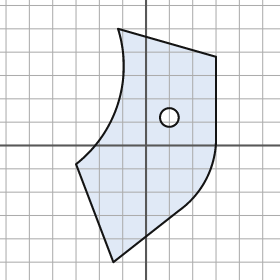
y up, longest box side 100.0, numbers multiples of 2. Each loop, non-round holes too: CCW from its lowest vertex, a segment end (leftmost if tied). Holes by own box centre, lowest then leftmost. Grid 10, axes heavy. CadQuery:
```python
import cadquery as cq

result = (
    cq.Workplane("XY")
    .moveTo(-14.0, -50.0)
    .lineTo(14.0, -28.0)
    .threePointArc((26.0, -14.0), (30.0, 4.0))
    .lineTo(30.0, 38.0)
    .lineTo(-12.0, 50.0)
    .threePointArc((-12.0, 18.0), (-30.0, -8.0))
    .close()
    .moveTo(10.0, 12.0)
    .circle(4.0)
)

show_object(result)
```